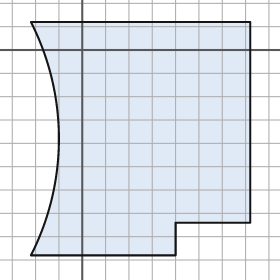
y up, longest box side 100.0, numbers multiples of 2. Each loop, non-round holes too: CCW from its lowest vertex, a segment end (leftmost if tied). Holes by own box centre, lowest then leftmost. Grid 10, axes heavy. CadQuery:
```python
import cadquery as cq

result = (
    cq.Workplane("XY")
    .moveTo(-22.0, -88.0)
    .lineTo(40.0, -88.0)
    .lineTo(40.0, -74.0)
    .lineTo(72.0, -74.0)
    .lineTo(72.0, 12.0)
    .lineTo(-22.0, 12.0)
    .threePointArc((-10.0, -38.0), (-22.0, -88.0))
    .close()
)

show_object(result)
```